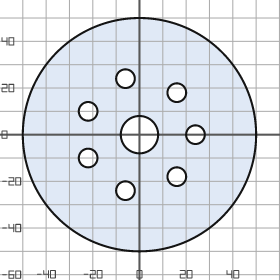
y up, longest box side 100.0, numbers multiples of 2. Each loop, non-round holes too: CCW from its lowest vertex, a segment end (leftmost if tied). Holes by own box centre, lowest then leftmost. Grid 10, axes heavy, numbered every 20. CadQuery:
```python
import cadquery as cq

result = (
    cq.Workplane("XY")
    .moveTo(0.0, 0.0)
    .circle(50.0)
    .moveTo(-6.0, -24.0)
    .circle(4.0)
    .moveTo(16.0, -18.0)
    .circle(4.0)
    .moveTo(-22.0, -10.0)
    .circle(4.0)
    .moveTo(0.0, 0.0)
    .circle(8.0)
    .moveTo(24.0, 0.0)
    .circle(4.0)
    .moveTo(-22.0, 10.0)
    .circle(4.0)
    .moveTo(16.0, 18.0)
    .circle(4.0)
    .moveTo(-6.0, 24.0)
    .circle(4.0)
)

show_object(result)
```